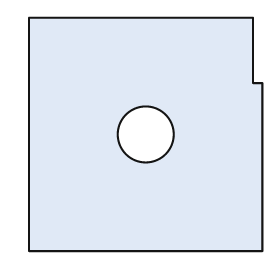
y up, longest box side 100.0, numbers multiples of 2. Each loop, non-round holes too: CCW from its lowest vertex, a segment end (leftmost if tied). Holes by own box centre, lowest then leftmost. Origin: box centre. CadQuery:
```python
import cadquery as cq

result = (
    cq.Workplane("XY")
    .moveTo(-50.0, -50.0)
    .lineTo(50.0, -50.0)
    .lineTo(50.0, 22.0)
    .lineTo(46.0, 22.0)
    .lineTo(46.0, 50.0)
    .lineTo(-50.0, 50.0)
    .close()
    .moveTo(0.0, 0.0)
    .circle(12.0)
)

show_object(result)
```